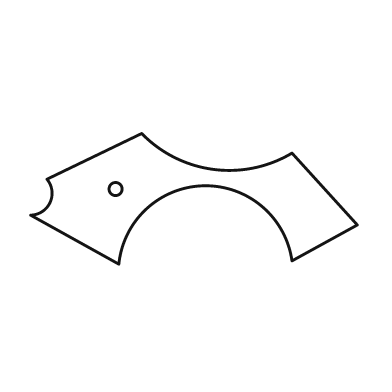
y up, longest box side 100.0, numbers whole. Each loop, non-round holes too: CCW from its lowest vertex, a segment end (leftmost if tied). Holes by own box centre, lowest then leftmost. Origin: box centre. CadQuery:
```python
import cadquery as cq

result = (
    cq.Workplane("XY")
    .moveTo(-23.0, -20.0)
    .threePointArc((3.0, 4.0), (30.0, -19.0))
    .lineTo(50.0, -8.0)
    .lineTo(30.0, 14.0)
    .threePointArc((6.0, 9.0), (-16.0, 20.0))
    .lineTo(-45.0, 6.0)
    .threePointArc((-44.0, -1.0), (-50.0, -5.0))
    .close()
    .moveTo(-24.0, 3.0)
    .circle(2.0)
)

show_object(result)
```